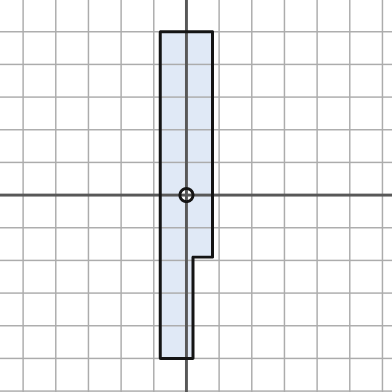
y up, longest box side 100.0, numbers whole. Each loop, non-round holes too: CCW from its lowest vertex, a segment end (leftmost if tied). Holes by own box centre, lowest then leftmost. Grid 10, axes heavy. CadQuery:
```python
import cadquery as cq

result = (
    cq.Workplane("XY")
    .moveTo(-8.0, -50.0)
    .lineTo(2.0, -50.0)
    .lineTo(2.0, -19.0)
    .lineTo(8.0, -19.0)
    .lineTo(8.0, 50.0)
    .lineTo(-8.0, 50.0)
    .close()
    .moveTo(0.0, 0.0)
    .circle(2.0)
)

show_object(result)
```